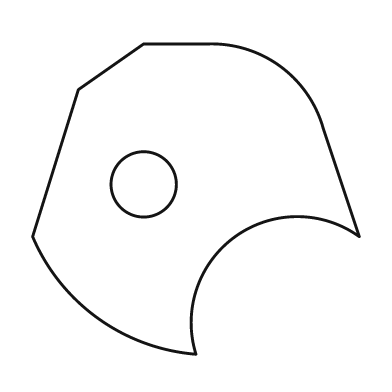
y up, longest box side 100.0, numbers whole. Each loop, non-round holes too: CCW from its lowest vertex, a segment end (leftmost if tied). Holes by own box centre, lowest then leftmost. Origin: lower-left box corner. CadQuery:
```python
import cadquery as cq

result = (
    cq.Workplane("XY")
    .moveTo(50.0, 0.0)
    .threePointArc((62.0, 36.0), (100.0, 36.0))
    .lineTo(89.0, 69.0)
    .threePointArc((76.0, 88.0), (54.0, 95.0))
    .lineTo(34.0, 95.0)
    .lineTo(14.0, 81.0)
    .lineTo(0.0, 36.0)
    .threePointArc((20.0, 11.0), (50.0, 0.0))
    .close()
    .moveTo(34.0, 52.0)
    .circle(10.0)
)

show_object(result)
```